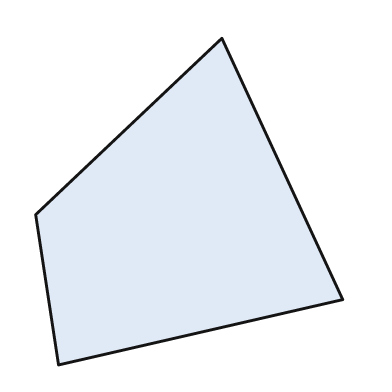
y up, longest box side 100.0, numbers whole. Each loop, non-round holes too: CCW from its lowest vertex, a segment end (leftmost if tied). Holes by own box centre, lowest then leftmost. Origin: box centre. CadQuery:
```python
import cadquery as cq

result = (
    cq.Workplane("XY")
    .moveTo(-40.0, -50.0)
    .lineTo(47.0, -30.0)
    .lineTo(10.0, 50.0)
    .lineTo(-47.0, -4.0)
    .close()
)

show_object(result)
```